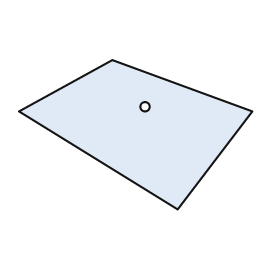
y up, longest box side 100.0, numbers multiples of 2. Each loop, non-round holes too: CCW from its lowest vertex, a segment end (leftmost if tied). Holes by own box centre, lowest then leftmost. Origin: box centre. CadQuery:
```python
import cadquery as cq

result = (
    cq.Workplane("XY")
    .moveTo(18.0, -32.0)
    .lineTo(50.0, 10.0)
    .lineTo(-10.0, 32.0)
    .lineTo(-50.0, 10.0)
    .close()
    .moveTo(4.0, 12.0)
    .circle(2.0)
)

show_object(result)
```